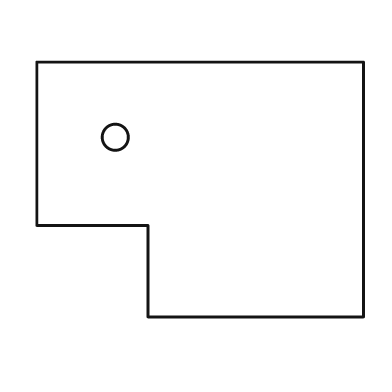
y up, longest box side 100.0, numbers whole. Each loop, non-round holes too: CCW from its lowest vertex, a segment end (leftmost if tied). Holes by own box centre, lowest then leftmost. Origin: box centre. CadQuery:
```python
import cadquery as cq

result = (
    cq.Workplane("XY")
    .moveTo(-16.0, -39.0)
    .lineTo(50.0, -39.0)
    .lineTo(50.0, 39.0)
    .lineTo(-50.0, 39.0)
    .lineTo(-50.0, -11.0)
    .lineTo(-16.0, -11.0)
    .close()
    .moveTo(-26.0, 16.0)
    .circle(4.0)
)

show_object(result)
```